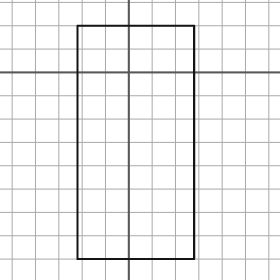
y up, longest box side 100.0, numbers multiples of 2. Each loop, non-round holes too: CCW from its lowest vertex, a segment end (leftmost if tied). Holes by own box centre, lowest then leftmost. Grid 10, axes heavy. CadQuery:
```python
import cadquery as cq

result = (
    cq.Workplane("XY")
    .moveTo(-22.0, -80.0)
    .lineTo(28.0, -80.0)
    .lineTo(28.0, 20.0)
    .lineTo(-22.0, 20.0)
    .close()
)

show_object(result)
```